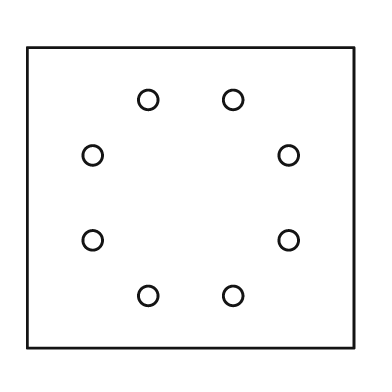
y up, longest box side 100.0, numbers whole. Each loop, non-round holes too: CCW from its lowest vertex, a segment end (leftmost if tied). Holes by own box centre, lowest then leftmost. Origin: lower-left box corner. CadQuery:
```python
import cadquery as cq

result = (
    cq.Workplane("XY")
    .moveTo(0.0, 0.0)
    .lineTo(100.0, 0.0)
    .lineTo(100.0, 92.0)
    .lineTo(0.0, 92.0)
    .close()
    .moveTo(37.0, 16.0)
    .circle(3.0)
    .moveTo(63.0, 16.0)
    .circle(3.0)
    .moveTo(20.0, 33.0)
    .circle(3.0)
    .moveTo(80.0, 33.0)
    .circle(3.0)
    .moveTo(20.0, 59.0)
    .circle(3.0)
    .moveTo(80.0, 59.0)
    .circle(3.0)
    .moveTo(37.0, 76.0)
    .circle(3.0)
    .moveTo(63.0, 76.0)
    .circle(3.0)
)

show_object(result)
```